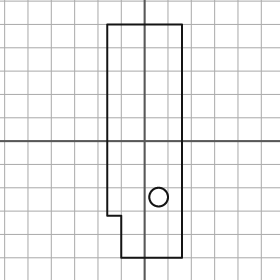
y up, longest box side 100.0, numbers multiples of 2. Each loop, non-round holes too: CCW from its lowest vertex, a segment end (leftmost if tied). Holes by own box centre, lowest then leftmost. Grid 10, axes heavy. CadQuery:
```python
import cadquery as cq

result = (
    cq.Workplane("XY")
    .moveTo(-10.0, -50.0)
    .lineTo(16.0, -50.0)
    .lineTo(16.0, 50.0)
    .lineTo(-16.0, 50.0)
    .lineTo(-16.0, -32.0)
    .lineTo(-10.0, -32.0)
    .close()
    .moveTo(6.0, -24.0)
    .circle(4.0)
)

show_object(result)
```